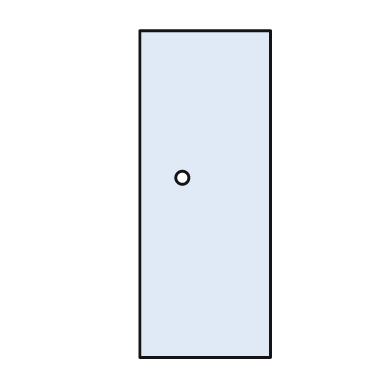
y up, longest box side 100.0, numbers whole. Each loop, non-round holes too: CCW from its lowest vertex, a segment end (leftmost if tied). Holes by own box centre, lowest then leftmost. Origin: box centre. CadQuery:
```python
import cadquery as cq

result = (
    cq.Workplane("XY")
    .moveTo(-20.0, -50.0)
    .lineTo(20.0, -50.0)
    .lineTo(20.0, 50.0)
    .lineTo(-20.0, 50.0)
    .close()
    .moveTo(-7.0, 5.0)
    .circle(2.0)
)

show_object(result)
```